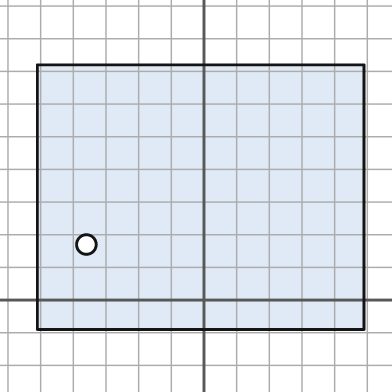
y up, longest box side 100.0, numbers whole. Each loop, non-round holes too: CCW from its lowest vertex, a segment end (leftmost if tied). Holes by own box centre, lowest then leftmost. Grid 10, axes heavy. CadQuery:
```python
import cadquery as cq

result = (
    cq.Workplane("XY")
    .moveTo(-51.0, -9.0)
    .lineTo(49.0, -9.0)
    .lineTo(49.0, 72.0)
    .lineTo(-51.0, 72.0)
    .close()
    .moveTo(-36.0, 17.0)
    .circle(3.0)
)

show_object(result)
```